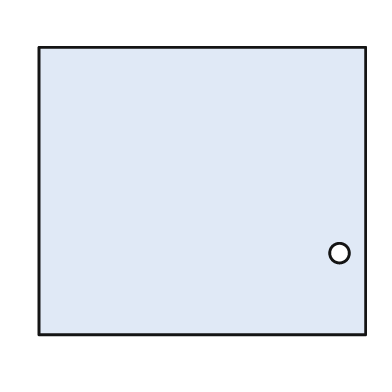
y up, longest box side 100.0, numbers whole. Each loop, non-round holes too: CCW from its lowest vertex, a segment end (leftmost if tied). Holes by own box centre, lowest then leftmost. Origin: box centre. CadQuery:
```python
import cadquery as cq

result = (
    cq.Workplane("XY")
    .moveTo(-50.0, -44.0)
    .lineTo(50.0, -44.0)
    .lineTo(50.0, 44.0)
    .lineTo(-50.0, 44.0)
    .close()
    .moveTo(42.0, -19.0)
    .circle(3.0)
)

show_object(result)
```